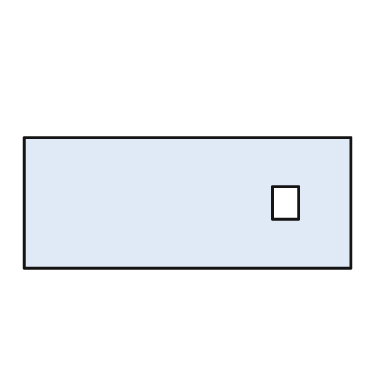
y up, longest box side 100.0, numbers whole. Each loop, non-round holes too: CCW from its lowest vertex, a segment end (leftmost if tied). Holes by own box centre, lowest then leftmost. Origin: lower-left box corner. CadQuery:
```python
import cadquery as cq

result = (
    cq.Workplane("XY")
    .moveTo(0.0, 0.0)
    .lineTo(100.0, 0.0)
    .lineTo(100.0, 40.0)
    .lineTo(0.0, 40.0)
    .close()
    .moveTo(76.0, 15.0)
    .lineTo(84.0, 15.0)
    .lineTo(84.0, 25.0)
    .lineTo(76.0, 25.0)
    .close()
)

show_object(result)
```